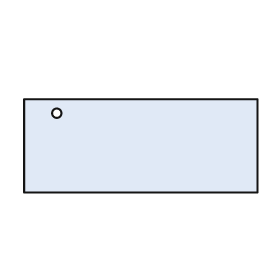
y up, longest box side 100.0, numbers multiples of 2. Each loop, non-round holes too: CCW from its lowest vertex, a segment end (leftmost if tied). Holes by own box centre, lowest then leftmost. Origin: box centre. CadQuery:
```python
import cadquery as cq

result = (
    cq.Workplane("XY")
    .moveTo(-50.0, -20.0)
    .lineTo(50.0, -20.0)
    .lineTo(50.0, 20.0)
    .lineTo(-50.0, 20.0)
    .close()
    .moveTo(-36.0, 14.0)
    .circle(2.0)
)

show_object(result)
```